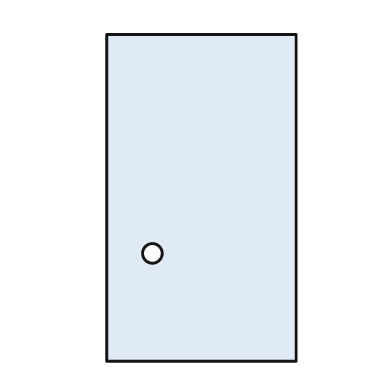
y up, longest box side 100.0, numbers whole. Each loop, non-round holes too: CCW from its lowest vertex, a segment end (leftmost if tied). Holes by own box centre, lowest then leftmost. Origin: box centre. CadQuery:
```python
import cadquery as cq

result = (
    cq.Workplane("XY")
    .moveTo(-29.0, -50.0)
    .lineTo(29.0, -50.0)
    .lineTo(29.0, 50.0)
    .lineTo(-29.0, 50.0)
    .close()
    .moveTo(-15.0, -17.0)
    .circle(3.0)
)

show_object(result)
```